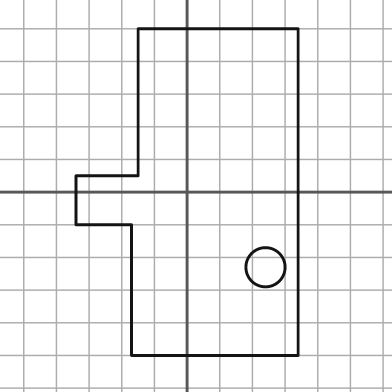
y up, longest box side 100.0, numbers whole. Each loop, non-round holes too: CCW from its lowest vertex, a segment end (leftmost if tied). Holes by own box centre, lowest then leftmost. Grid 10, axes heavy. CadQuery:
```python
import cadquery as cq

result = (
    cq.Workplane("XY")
    .moveTo(-17.0, -50.0)
    .lineTo(34.0, -50.0)
    .lineTo(34.0, 50.0)
    .lineTo(-15.0, 50.0)
    .lineTo(-15.0, 5.0)
    .lineTo(-34.0, 5.0)
    .lineTo(-34.0, -10.0)
    .lineTo(-17.0, -10.0)
    .close()
    .moveTo(24.0, -23.0)
    .circle(6.0)
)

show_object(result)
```